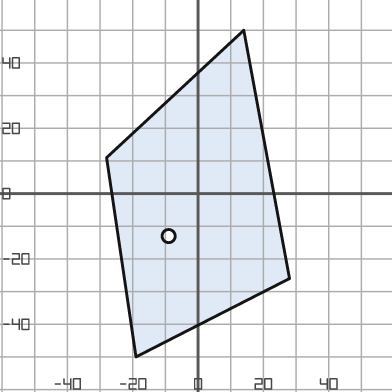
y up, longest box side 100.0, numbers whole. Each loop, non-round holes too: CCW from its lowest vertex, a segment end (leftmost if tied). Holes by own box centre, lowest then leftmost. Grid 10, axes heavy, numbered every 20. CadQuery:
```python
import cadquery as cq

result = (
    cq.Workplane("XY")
    .moveTo(-19.0, -50.0)
    .lineTo(28.0, -26.0)
    .lineTo(14.0, 50.0)
    .lineTo(-28.0, 11.0)
    .close()
    .moveTo(-9.0, -13.0)
    .circle(2.0)
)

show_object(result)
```